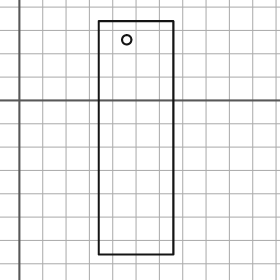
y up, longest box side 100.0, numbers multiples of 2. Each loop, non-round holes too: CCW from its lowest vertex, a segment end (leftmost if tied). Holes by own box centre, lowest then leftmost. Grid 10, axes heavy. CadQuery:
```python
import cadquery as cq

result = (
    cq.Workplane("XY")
    .moveTo(34.0, -66.0)
    .lineTo(66.0, -66.0)
    .lineTo(66.0, 34.0)
    .lineTo(34.0, 34.0)
    .close()
    .moveTo(46.0, 26.0)
    .circle(2.0)
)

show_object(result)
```